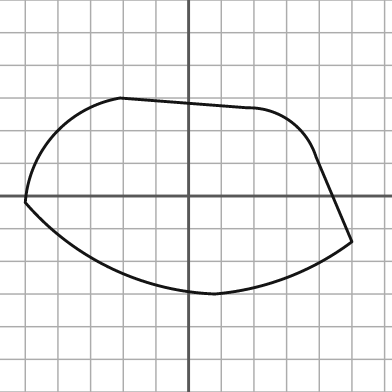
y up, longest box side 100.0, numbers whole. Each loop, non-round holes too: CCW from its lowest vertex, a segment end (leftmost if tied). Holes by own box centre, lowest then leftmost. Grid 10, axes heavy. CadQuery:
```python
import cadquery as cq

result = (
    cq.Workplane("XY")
    .moveTo(8.0, -30.0)
    .threePointArc((30.0, -25.0), (50.0, -14.0))
    .lineTo(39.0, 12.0)
    .threePointArc((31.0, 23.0), (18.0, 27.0))
    .lineTo(-21.0, 30.0)
    .threePointArc((-41.0, 19.0), (-50.0, -2.0))
    .threePointArc((-24.0, -22.0), (8.0, -30.0))
    .close()
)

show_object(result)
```